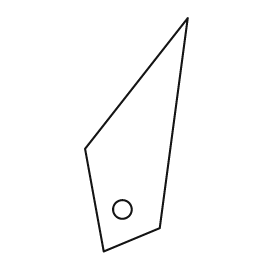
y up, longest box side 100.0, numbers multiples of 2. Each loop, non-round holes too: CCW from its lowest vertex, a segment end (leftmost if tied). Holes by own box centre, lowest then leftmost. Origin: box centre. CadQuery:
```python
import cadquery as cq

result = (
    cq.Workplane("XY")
    .moveTo(-14.0, -50.0)
    .lineTo(10.0, -40.0)
    .lineTo(22.0, 50.0)
    .lineTo(-22.0, -6.0)
    .close()
    .moveTo(-6.0, -32.0)
    .circle(4.0)
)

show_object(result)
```